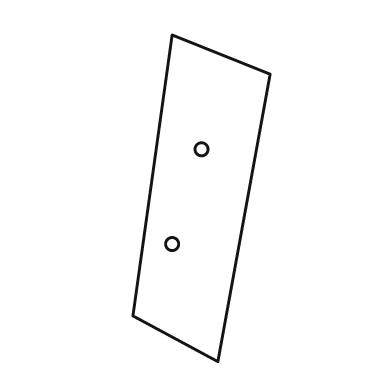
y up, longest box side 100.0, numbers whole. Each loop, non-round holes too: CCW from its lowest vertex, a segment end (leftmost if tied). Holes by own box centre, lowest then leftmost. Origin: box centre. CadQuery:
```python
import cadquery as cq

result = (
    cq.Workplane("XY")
    .moveTo(5.0, -50.0)
    .lineTo(21.0, 38.0)
    .lineTo(-9.0, 50.0)
    .lineTo(-21.0, -36.0)
    .close()
    .moveTo(-9.0, -14.0)
    .circle(2.0)
    .moveTo(0.0, 15.0)
    .circle(2.0)
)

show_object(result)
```